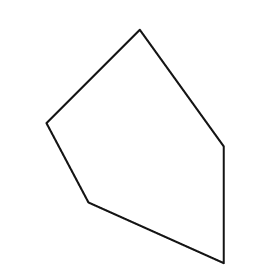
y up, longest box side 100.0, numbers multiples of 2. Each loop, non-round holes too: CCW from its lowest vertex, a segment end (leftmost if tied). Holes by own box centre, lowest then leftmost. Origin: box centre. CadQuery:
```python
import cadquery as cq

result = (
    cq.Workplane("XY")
    .moveTo(38.0, -50.0)
    .lineTo(38.0, 0.0)
    .lineTo(2.0, 50.0)
    .lineTo(-38.0, 10.0)
    .lineTo(-20.0, -24.0)
    .close()
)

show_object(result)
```